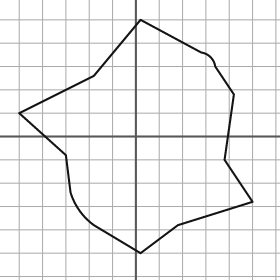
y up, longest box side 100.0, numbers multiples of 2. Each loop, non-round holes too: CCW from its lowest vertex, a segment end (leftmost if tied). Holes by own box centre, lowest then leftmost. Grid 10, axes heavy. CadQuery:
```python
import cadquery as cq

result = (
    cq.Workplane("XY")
    .moveTo(2.0, -50.0)
    .lineTo(18.0, -38.0)
    .lineTo(50.0, -28.0)
    .lineTo(38.0, -10.0)
    .lineTo(42.0, 18.0)
    .lineTo(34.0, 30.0)
    .threePointArc((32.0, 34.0), (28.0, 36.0))
    .lineTo(2.0, 50.0)
    .lineTo(-18.0, 26.0)
    .lineTo(-50.0, 10.0)
    .lineTo(-30.0, -8.0)
    .lineTo(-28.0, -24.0)
    .threePointArc((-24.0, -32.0), (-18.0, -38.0))
    .close()
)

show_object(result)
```